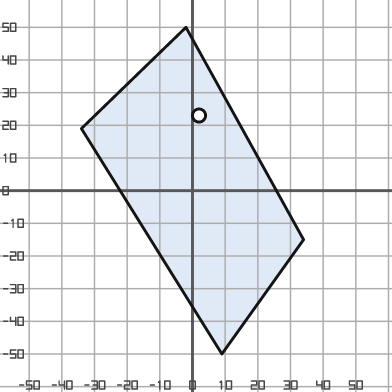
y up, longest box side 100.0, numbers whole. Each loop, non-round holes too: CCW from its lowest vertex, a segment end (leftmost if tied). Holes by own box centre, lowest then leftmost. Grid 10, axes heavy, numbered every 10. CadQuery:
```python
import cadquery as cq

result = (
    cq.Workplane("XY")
    .moveTo(9.0, -50.0)
    .lineTo(34.0, -15.0)
    .lineTo(-2.0, 50.0)
    .lineTo(-34.0, 19.0)
    .close()
    .moveTo(2.0, 23.0)
    .circle(2.0)
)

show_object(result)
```